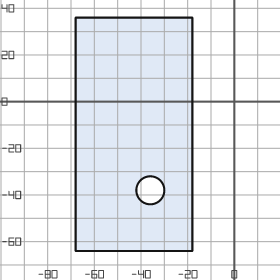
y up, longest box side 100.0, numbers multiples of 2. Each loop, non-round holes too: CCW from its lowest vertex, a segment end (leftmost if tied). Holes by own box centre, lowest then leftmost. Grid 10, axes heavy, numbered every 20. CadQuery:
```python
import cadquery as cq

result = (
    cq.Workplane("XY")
    .moveTo(-68.0, -64.0)
    .lineTo(-18.0, -64.0)
    .lineTo(-18.0, 36.0)
    .lineTo(-68.0, 36.0)
    .close()
    .moveTo(-36.0, -38.0)
    .circle(6.0)
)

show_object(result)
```